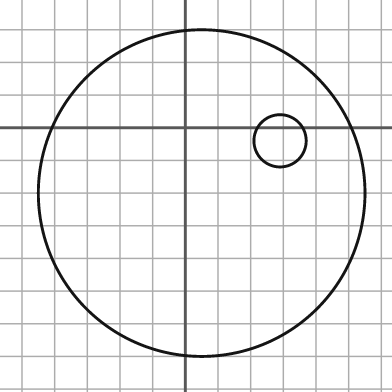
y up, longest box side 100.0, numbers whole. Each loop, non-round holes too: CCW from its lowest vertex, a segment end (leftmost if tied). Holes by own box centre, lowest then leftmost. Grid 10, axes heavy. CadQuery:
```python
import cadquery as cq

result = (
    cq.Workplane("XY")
    .moveTo(5.0, -20.0)
    .circle(50.0)
    .moveTo(29.0, -4.0)
    .circle(8.0)
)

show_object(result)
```